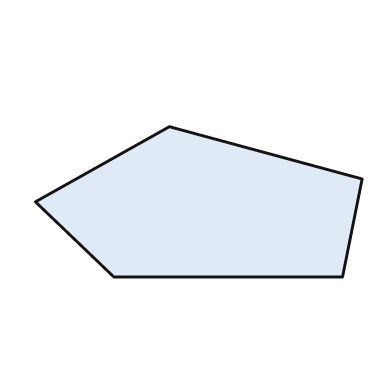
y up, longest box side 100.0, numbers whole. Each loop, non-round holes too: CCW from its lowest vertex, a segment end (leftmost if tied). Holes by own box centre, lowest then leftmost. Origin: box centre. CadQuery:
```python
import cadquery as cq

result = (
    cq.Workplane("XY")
    .moveTo(-26.0, -23.0)
    .lineTo(44.0, -23.0)
    .lineTo(50.0, 7.0)
    .lineTo(-9.0, 23.0)
    .lineTo(-50.0, 0.0)
    .close()
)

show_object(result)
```